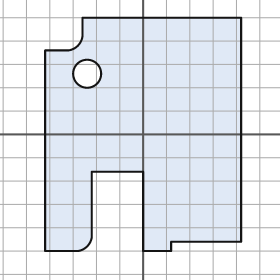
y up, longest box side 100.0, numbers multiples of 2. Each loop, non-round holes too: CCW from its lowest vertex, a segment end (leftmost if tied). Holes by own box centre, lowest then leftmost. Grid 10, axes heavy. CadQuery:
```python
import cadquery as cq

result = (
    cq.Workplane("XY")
    .moveTo(-42.0, -50.0)
    .lineTo(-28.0, -50.0)
    .threePointArc((-24.0, -48.0), (-22.0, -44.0))
    .lineTo(-22.0, -16.0)
    .lineTo(0.0, -16.0)
    .lineTo(0.0, -50.0)
    .lineTo(12.0, -50.0)
    .lineTo(12.0, -46.0)
    .lineTo(42.0, -46.0)
    .lineTo(42.0, 50.0)
    .lineTo(-26.0, 50.0)
    .lineTo(-26.0, 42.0)
    .threePointArc((-28.0, 38.0), (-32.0, 36.0))
    .lineTo(-42.0, 36.0)
    .close()
    .moveTo(-24.0, 26.0)
    .circle(6.0)
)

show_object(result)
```